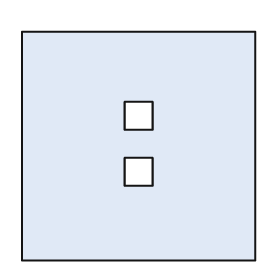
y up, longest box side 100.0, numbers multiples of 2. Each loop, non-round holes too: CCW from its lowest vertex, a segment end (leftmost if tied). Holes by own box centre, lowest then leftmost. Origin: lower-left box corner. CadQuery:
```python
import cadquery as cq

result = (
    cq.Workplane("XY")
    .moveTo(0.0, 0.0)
    .lineTo(100.0, 0.0)
    .lineTo(100.0, 98.0)
    .lineTo(0.0, 98.0)
    .close()
    .moveTo(44.0, 32.0)
    .lineTo(56.0, 32.0)
    .lineTo(56.0, 44.0)
    .lineTo(44.0, 44.0)
    .close()
    .moveTo(44.0, 56.0)
    .lineTo(56.0, 56.0)
    .lineTo(56.0, 68.0)
    .lineTo(44.0, 68.0)
    .close()
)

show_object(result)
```